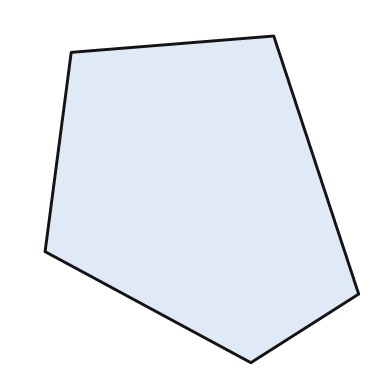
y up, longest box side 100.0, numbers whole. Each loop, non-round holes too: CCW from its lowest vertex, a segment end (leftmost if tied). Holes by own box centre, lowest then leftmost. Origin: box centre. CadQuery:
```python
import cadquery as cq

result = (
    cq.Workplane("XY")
    .moveTo(15.0, -50.0)
    .lineTo(48.0, -29.0)
    .lineTo(22.0, 50.0)
    .lineTo(-40.0, 45.0)
    .lineTo(-48.0, -16.0)
    .close()
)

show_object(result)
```